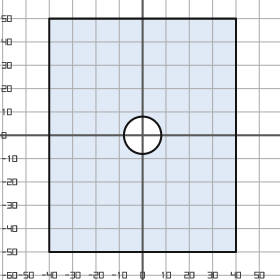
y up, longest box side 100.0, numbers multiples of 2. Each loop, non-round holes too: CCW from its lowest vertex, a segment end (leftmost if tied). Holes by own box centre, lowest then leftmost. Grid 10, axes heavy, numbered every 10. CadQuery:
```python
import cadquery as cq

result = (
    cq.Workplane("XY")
    .moveTo(-40.0, -50.0)
    .lineTo(40.0, -50.0)
    .lineTo(40.0, 50.0)
    .lineTo(-40.0, 50.0)
    .close()
    .moveTo(0.0, 0.0)
    .circle(8.0)
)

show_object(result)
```